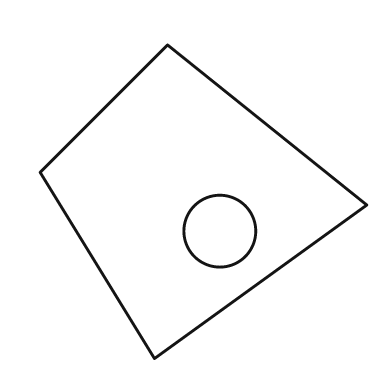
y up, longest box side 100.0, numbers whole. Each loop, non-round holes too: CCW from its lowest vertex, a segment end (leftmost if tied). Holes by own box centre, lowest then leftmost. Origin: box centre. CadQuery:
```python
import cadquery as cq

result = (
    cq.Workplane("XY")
    .moveTo(-15.0, -48.0)
    .lineTo(50.0, -1.0)
    .lineTo(-11.0, 48.0)
    .lineTo(-50.0, 9.0)
    .close()
    .moveTo(5.0, -9.0)
    .circle(11.0)
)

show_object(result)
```